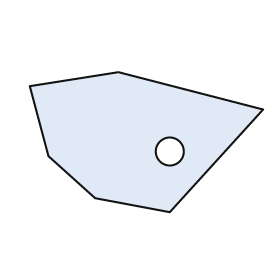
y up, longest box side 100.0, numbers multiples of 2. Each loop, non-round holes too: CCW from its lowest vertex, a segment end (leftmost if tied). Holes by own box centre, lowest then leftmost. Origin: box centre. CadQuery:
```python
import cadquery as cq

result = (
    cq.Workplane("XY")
    .moveTo(10.0, -30.0)
    .lineTo(50.0, 14.0)
    .lineTo(-12.0, 30.0)
    .lineTo(-50.0, 24.0)
    .lineTo(-42.0, -6.0)
    .lineTo(-22.0, -24.0)
    .close()
    .moveTo(10.0, -4.0)
    .circle(6.0)
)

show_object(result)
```